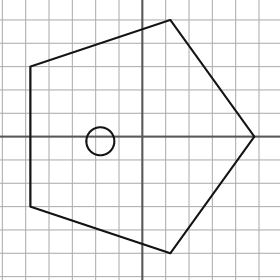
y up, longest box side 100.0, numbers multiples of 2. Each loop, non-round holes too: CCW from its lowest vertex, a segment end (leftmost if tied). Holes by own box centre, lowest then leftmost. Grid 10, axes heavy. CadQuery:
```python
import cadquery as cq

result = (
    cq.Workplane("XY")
    .moveTo(12.0, -50.0)
    .lineTo(48.0, 0.0)
    .lineTo(12.0, 50.0)
    .lineTo(-48.0, 30.0)
    .lineTo(-48.0, -30.0)
    .close()
    .moveTo(-18.0, -2.0)
    .circle(6.0)
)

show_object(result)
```